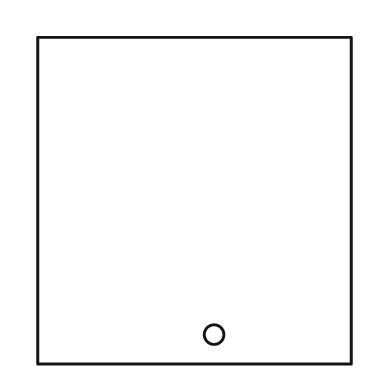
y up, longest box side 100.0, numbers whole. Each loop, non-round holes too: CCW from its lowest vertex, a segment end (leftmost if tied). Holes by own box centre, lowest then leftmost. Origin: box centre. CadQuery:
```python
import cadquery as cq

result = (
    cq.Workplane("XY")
    .moveTo(-48.0, -50.0)
    .lineTo(48.0, -50.0)
    .lineTo(48.0, 50.0)
    .lineTo(-48.0, 50.0)
    .close()
    .moveTo(6.0, -41.0)
    .circle(3.0)
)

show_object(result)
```